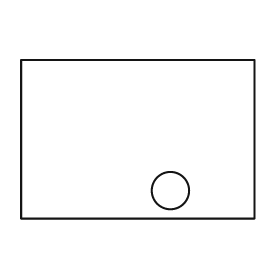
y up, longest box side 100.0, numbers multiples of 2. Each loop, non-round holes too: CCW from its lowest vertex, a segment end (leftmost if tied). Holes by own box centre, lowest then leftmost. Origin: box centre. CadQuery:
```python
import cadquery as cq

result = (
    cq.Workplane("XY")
    .moveTo(-50.0, -34.0)
    .lineTo(50.0, -34.0)
    .lineTo(50.0, 34.0)
    .lineTo(-50.0, 34.0)
    .close()
    .moveTo(14.0, -22.0)
    .circle(8.0)
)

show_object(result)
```